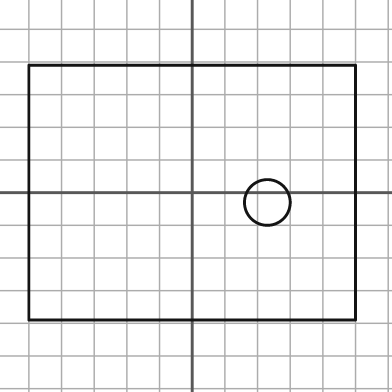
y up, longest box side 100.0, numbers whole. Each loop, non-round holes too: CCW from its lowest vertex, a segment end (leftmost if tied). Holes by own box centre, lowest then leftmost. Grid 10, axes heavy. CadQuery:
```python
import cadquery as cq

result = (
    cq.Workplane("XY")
    .moveTo(-50.0, -39.0)
    .lineTo(50.0, -39.0)
    .lineTo(50.0, 39.0)
    .lineTo(-50.0, 39.0)
    .close()
    .moveTo(23.0, -3.0)
    .circle(7.0)
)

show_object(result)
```